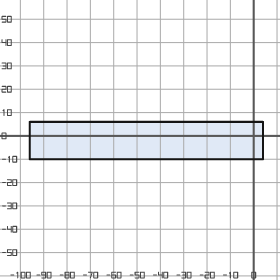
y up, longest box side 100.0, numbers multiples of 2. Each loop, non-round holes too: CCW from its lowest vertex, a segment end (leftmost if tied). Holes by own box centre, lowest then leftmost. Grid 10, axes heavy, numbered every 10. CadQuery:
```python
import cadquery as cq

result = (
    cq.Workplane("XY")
    .moveTo(-96.0, -10.0)
    .lineTo(4.0, -10.0)
    .lineTo(4.0, 6.0)
    .lineTo(-96.0, 6.0)
    .close()
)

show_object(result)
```